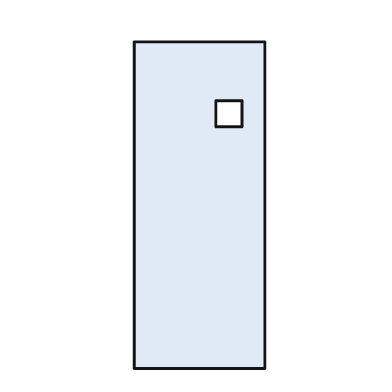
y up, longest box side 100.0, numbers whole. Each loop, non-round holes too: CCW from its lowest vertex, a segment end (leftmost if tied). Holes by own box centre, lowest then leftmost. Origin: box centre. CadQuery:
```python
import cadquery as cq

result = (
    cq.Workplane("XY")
    .moveTo(-20.0, -50.0)
    .lineTo(20.0, -50.0)
    .lineTo(20.0, 50.0)
    .lineTo(-20.0, 50.0)
    .close()
    .moveTo(5.0, 24.0)
    .lineTo(13.0, 24.0)
    .lineTo(13.0, 32.0)
    .lineTo(5.0, 32.0)
    .close()
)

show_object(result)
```